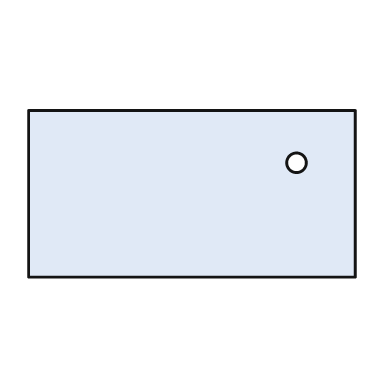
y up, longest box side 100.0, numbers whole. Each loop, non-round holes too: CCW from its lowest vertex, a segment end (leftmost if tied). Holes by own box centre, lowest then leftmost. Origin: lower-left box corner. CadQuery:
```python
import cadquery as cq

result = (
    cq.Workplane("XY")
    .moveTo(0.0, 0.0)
    .lineTo(100.0, 0.0)
    .lineTo(100.0, 51.0)
    .lineTo(0.0, 51.0)
    .close()
    .moveTo(82.0, 35.0)
    .circle(3.0)
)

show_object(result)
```